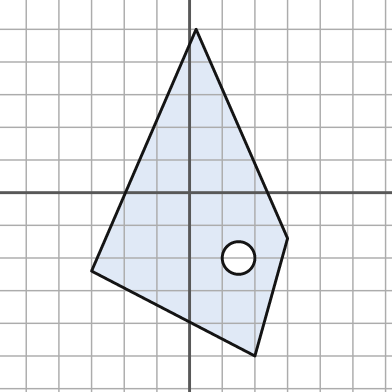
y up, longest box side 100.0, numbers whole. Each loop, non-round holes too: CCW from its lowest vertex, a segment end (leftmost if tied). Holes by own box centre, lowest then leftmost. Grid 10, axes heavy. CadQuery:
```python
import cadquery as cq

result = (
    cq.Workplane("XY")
    .moveTo(20.0, -50.0)
    .lineTo(30.0, -14.0)
    .lineTo(2.0, 50.0)
    .lineTo(-30.0, -24.0)
    .close()
    .moveTo(15.0, -20.0)
    .circle(5.0)
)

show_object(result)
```